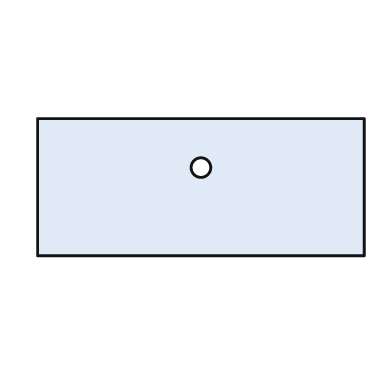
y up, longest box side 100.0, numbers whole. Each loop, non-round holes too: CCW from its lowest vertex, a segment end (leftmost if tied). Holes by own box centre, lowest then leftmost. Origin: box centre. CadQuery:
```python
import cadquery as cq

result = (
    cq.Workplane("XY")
    .moveTo(-50.0, -21.0)
    .lineTo(50.0, -21.0)
    .lineTo(50.0, 21.0)
    .lineTo(-50.0, 21.0)
    .close()
    .moveTo(0.0, 6.0)
    .circle(3.0)
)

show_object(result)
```